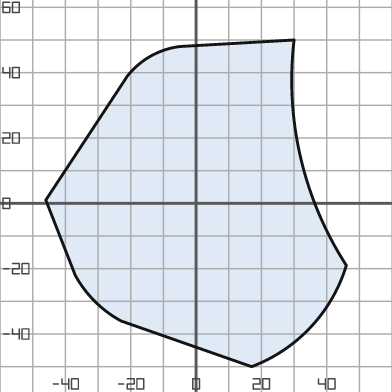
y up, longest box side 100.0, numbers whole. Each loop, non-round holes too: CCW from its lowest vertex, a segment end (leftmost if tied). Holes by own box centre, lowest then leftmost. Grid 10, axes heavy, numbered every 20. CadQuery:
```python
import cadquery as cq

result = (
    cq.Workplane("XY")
    .moveTo(17.0, -50.0)
    .threePointArc((35.0, -38.0), (46.0, -19.0))
    .threePointArc((32.0, 14.0), (30.0, 50.0))
    .lineTo(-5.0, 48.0)
    .threePointArc((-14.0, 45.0), (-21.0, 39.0))
    .lineTo(-46.0, 1.0)
    .lineTo(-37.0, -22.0)
    .threePointArc((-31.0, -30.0), (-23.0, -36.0))
    .close()
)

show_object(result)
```